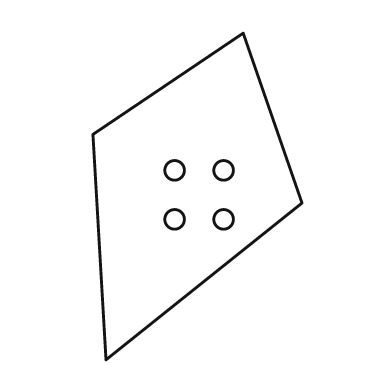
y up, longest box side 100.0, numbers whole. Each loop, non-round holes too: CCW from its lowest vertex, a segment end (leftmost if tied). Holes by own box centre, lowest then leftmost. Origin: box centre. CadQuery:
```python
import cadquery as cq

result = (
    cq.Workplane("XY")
    .moveTo(-28.0, -50.0)
    .lineTo(32.0, -2.0)
    .lineTo(14.0, 50.0)
    .lineTo(-32.0, 19.0)
    .close()
    .moveTo(-7.0, -7.0)
    .circle(3.0)
    .moveTo(8.0, -7.0)
    .circle(3.0)
    .moveTo(-7.0, 8.0)
    .circle(3.0)
    .moveTo(8.0, 8.0)
    .circle(3.0)
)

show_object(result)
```